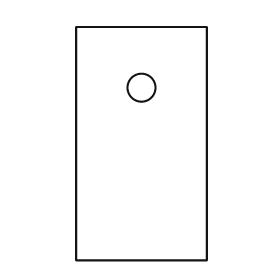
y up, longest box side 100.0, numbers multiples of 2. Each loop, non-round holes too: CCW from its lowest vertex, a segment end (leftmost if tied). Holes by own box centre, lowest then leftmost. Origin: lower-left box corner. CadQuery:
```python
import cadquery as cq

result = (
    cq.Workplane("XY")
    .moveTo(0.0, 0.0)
    .lineTo(56.0, 0.0)
    .lineTo(56.0, 100.0)
    .lineTo(0.0, 100.0)
    .close()
    .moveTo(28.0, 74.0)
    .circle(6.0)
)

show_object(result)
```